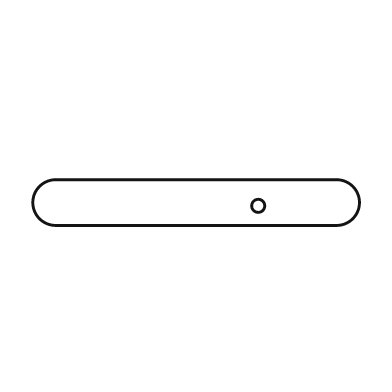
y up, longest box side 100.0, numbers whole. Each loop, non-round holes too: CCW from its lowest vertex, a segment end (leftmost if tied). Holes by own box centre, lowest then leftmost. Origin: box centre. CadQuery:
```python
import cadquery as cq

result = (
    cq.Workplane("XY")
    .moveTo(-43.0, -7.0)
    .lineTo(43.0, -7.0)
    .threePointArc((50.0, 0.0), (43.0, 7.0))
    .lineTo(-43.0, 7.0)
    .threePointArc((-50.0, 0.0), (-43.0, -7.0))
    .close()
    .moveTo(19.0, -1.0)
    .circle(2.0)
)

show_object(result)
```